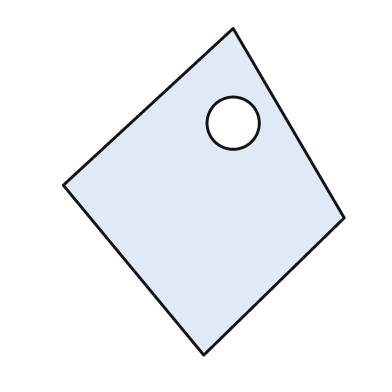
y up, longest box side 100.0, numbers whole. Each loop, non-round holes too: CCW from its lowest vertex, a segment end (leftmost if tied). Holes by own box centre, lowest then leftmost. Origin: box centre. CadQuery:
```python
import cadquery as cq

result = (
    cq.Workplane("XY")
    .moveTo(0.0, -50.0)
    .lineTo(43.0, -8.0)
    .lineTo(9.0, 50.0)
    .lineTo(-43.0, 2.0)
    .close()
    .moveTo(9.0, 21.0)
    .circle(8.0)
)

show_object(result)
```